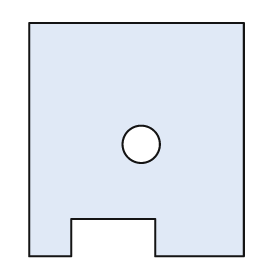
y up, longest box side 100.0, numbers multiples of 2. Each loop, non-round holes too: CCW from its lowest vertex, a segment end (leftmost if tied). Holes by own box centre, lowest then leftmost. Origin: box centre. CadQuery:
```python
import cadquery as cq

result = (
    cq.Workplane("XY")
    .moveTo(-46.0, -50.0)
    .lineTo(-28.0, -50.0)
    .lineTo(-28.0, -34.0)
    .lineTo(8.0, -34.0)
    .lineTo(8.0, -50.0)
    .lineTo(46.0, -50.0)
    .lineTo(46.0, 50.0)
    .lineTo(-46.0, 50.0)
    .close()
    .moveTo(2.0, -2.0)
    .circle(8.0)
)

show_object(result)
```